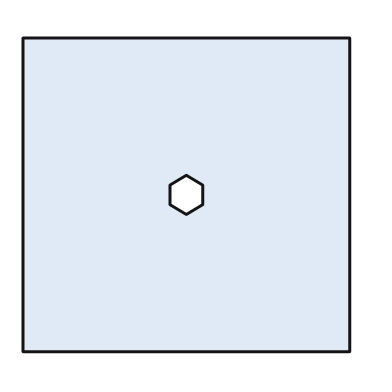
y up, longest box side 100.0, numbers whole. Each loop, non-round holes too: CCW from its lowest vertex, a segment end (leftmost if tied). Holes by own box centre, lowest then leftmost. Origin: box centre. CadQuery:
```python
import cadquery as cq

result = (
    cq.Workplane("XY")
    .moveTo(-50.0, -48.0)
    .lineTo(50.0, -48.0)
    .lineTo(50.0, 48.0)
    .lineTo(-50.0, 48.0)
    .close()
    .moveTo(0.0, -6.0)
    .lineTo(5.0, -3.0)
    .lineTo(5.0, 3.0)
    .lineTo(0.0, 6.0)
    .lineTo(-5.0, 3.0)
    .lineTo(-5.0, -3.0)
    .close()
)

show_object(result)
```